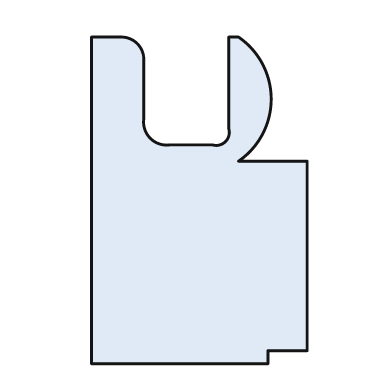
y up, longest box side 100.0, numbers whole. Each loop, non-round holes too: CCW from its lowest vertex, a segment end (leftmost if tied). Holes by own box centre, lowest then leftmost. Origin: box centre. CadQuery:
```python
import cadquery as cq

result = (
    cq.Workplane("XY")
    .moveTo(-33.0, -50.0)
    .lineTo(21.0, -50.0)
    .lineTo(21.0, -46.0)
    .lineTo(33.0, -46.0)
    .lineTo(33.0, 12.0)
    .lineTo(12.0, 12.0)
    .threePointArc((22.0, 31.0), (12.0, 50.0))
    .lineTo(9.0, 50.0)
    .lineTo(9.0, 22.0)
    .threePointArc((8.0, 18.0), (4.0, 17.0))
    .lineTo(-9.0, 17.0)
    .threePointArc((-15.0, 19.0), (-17.0, 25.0))
    .lineTo(-17.0, 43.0)
    .threePointArc((-19.0, 48.0), (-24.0, 50.0))
    .lineTo(-33.0, 50.0)
    .close()
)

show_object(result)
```